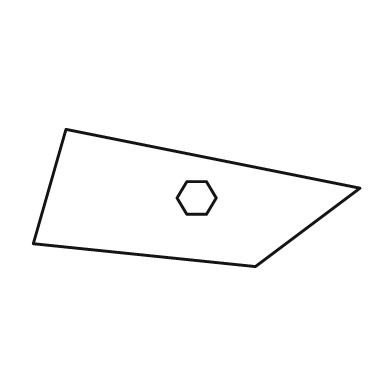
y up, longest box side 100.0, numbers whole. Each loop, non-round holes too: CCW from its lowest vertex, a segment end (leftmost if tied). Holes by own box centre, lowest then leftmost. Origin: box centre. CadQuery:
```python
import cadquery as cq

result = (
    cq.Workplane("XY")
    .moveTo(18.0, -21.0)
    .lineTo(50.0, 3.0)
    .lineTo(-40.0, 21.0)
    .lineTo(-50.0, -14.0)
    .close()
    .moveTo(-3.0, -5.0)
    .lineTo(3.0, -5.0)
    .lineTo(6.0, 0.0)
    .lineTo(3.0, 5.0)
    .lineTo(-3.0, 5.0)
    .lineTo(-6.0, 0.0)
    .close()
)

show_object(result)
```